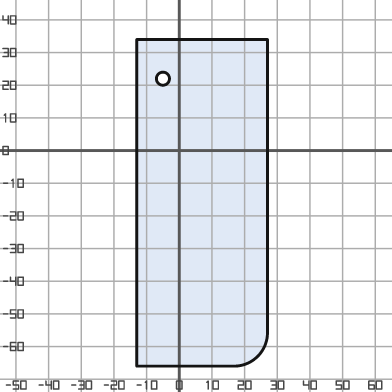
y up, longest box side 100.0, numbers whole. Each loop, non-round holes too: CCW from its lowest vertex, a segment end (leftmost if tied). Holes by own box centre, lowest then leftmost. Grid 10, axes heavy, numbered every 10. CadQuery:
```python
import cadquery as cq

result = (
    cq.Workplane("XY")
    .moveTo(-13.0, -66.0)
    .lineTo(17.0, -66.0)
    .threePointArc((24.0, -63.0), (27.0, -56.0))
    .lineTo(27.0, 34.0)
    .lineTo(-13.0, 34.0)
    .close()
    .moveTo(-5.0, 22.0)
    .circle(2.0)
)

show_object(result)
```